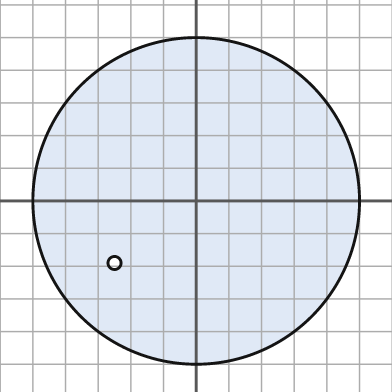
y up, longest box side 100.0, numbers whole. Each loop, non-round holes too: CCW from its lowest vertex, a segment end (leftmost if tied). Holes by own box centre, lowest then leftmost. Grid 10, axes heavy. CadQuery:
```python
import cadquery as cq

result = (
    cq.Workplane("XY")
    .moveTo(0.0, 0.0)
    .circle(50.0)
    .moveTo(-25.0, -19.0)
    .circle(2.0)
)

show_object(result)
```